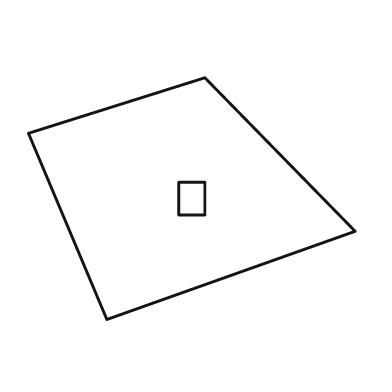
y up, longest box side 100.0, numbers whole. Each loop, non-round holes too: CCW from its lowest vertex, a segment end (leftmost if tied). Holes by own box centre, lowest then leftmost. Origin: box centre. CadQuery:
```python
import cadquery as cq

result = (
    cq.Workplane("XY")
    .moveTo(-26.0, -37.0)
    .lineTo(50.0, -10.0)
    .lineTo(4.0, 37.0)
    .lineTo(-50.0, 20.0)
    .close()
    .moveTo(-4.0, -5.0)
    .lineTo(4.0, -5.0)
    .lineTo(4.0, 5.0)
    .lineTo(-4.0, 5.0)
    .close()
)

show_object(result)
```